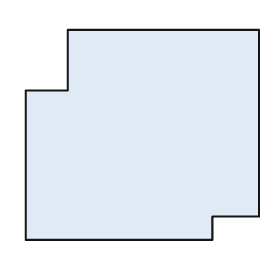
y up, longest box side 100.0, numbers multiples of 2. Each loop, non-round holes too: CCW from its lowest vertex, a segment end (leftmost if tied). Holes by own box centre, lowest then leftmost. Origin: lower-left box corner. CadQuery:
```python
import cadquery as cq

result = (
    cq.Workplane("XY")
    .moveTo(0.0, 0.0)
    .lineTo(80.0, 0.0)
    .lineTo(80.0, 10.0)
    .lineTo(100.0, 10.0)
    .lineTo(100.0, 90.0)
    .lineTo(18.0, 90.0)
    .lineTo(18.0, 64.0)
    .lineTo(0.0, 64.0)
    .close()
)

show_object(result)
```